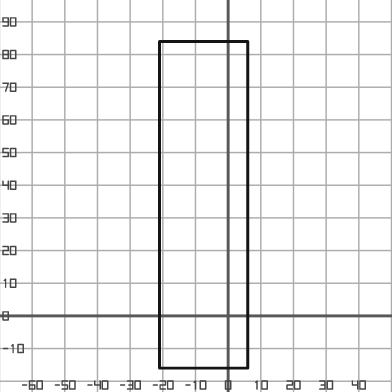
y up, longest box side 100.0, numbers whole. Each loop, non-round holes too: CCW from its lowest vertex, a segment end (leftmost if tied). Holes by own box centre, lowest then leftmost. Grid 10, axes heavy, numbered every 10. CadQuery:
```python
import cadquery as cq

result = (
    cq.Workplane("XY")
    .moveTo(-21.0, -16.0)
    .lineTo(6.0, -16.0)
    .lineTo(6.0, 84.0)
    .lineTo(-21.0, 84.0)
    .close()
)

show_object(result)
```